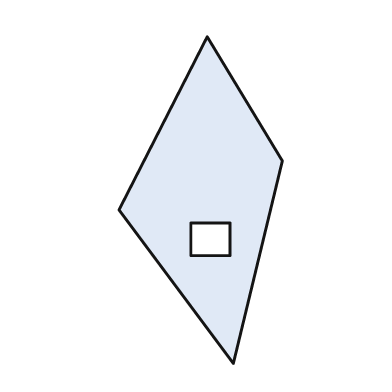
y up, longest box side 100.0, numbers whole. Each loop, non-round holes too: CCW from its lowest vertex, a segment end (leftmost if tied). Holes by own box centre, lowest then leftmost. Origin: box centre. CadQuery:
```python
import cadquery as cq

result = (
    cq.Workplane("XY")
    .moveTo(10.0, -50.0)
    .lineTo(25.0, 12.0)
    .lineTo(2.0, 50.0)
    .lineTo(-25.0, -3.0)
    .close()
    .moveTo(-3.0, -17.0)
    .lineTo(9.0, -17.0)
    .lineTo(9.0, -7.0)
    .lineTo(-3.0, -7.0)
    .close()
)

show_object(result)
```